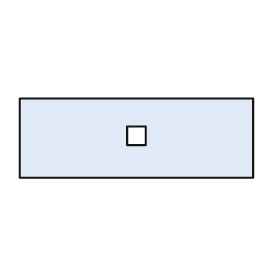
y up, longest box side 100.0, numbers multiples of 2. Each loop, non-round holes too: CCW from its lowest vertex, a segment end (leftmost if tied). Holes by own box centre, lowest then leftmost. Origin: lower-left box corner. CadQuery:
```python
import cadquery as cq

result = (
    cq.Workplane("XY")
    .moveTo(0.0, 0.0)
    .lineTo(100.0, 0.0)
    .lineTo(100.0, 34.0)
    .lineTo(0.0, 34.0)
    .close()
    .moveTo(46.0, 14.0)
    .lineTo(54.0, 14.0)
    .lineTo(54.0, 22.0)
    .lineTo(46.0, 22.0)
    .close()
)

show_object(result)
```